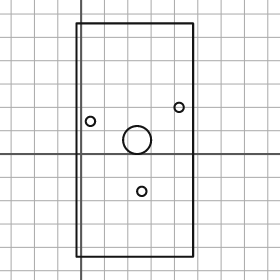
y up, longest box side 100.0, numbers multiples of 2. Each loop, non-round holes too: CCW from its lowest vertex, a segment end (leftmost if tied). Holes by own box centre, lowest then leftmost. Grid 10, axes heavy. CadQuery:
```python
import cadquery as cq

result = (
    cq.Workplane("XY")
    .moveTo(-2.0, -44.0)
    .lineTo(48.0, -44.0)
    .lineTo(48.0, 56.0)
    .lineTo(-2.0, 56.0)
    .close()
    .moveTo(26.0, -16.0)
    .circle(2.0)
    .moveTo(24.0, 6.0)
    .circle(6.0)
    .moveTo(4.0, 14.0)
    .circle(2.0)
    .moveTo(42.0, 20.0)
    .circle(2.0)
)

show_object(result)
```